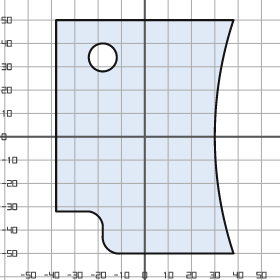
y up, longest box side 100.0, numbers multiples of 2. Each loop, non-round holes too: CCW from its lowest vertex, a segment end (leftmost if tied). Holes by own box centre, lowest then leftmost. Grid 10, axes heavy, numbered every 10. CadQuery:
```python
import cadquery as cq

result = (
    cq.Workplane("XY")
    .moveTo(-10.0, -50.0)
    .lineTo(38.0, -50.0)
    .threePointArc((30.0, 0.0), (38.0, 50.0))
    .lineTo(-38.0, 50.0)
    .lineTo(-38.0, -32.0)
    .lineTo(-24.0, -32.0)
    .threePointArc((-20.0, -34.0), (-18.0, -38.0))
    .lineTo(-18.0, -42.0)
    .threePointArc((-16.0, -48.0), (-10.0, -50.0))
    .close()
    .moveTo(-18.0, 34.0)
    .circle(6.0)
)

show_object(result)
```